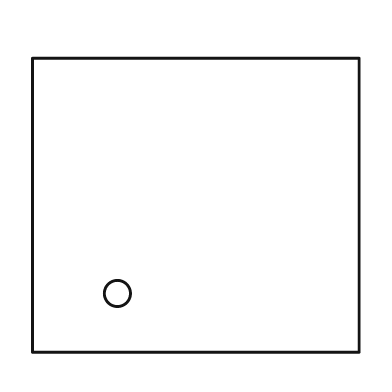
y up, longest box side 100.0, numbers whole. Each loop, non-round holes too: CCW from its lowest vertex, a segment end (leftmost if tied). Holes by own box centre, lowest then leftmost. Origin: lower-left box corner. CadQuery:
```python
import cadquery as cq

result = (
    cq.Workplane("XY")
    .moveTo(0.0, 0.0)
    .lineTo(100.0, 0.0)
    .lineTo(100.0, 90.0)
    .lineTo(0.0, 90.0)
    .close()
    .moveTo(26.0, 18.0)
    .circle(4.0)
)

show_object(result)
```